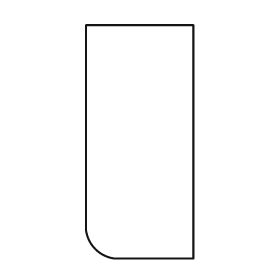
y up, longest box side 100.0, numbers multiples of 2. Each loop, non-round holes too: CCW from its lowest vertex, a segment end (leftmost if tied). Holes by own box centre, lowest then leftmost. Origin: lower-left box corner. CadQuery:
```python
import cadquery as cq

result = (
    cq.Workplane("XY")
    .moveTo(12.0, 0.0)
    .lineTo(46.0, 0.0)
    .lineTo(46.0, 100.0)
    .lineTo(0.0, 100.0)
    .lineTo(0.0, 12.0)
    .threePointArc((4.0, 4.0), (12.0, 0.0))
    .close()
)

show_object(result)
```